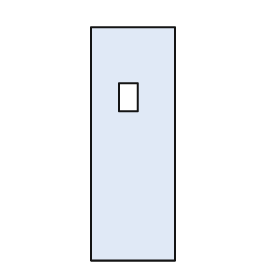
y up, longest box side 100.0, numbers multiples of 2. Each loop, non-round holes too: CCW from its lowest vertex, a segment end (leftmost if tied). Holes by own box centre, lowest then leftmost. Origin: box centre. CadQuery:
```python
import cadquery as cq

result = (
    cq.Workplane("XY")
    .moveTo(-18.0, -50.0)
    .lineTo(18.0, -50.0)
    .lineTo(18.0, 50.0)
    .lineTo(-18.0, 50.0)
    .close()
    .moveTo(-6.0, 14.0)
    .lineTo(2.0, 14.0)
    .lineTo(2.0, 26.0)
    .lineTo(-6.0, 26.0)
    .close()
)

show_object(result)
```